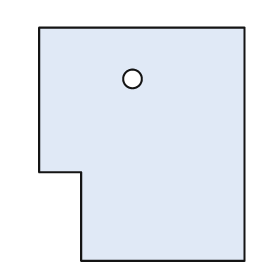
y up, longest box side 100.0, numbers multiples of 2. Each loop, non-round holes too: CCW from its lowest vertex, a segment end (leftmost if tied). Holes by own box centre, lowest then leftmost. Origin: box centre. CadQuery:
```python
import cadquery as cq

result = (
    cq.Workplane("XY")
    .moveTo(-26.0, -50.0)
    .lineTo(44.0, -50.0)
    .lineTo(44.0, 50.0)
    .lineTo(-44.0, 50.0)
    .lineTo(-44.0, -12.0)
    .lineTo(-26.0, -12.0)
    .close()
    .moveTo(-4.0, 28.0)
    .circle(4.0)
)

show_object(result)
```